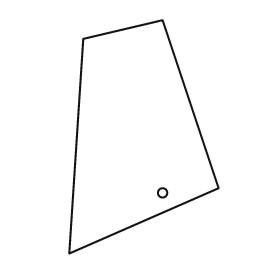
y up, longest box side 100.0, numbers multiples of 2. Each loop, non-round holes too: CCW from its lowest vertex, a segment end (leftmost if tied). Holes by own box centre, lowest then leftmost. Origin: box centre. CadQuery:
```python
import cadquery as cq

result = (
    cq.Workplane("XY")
    .moveTo(-32.0, -50.0)
    .lineTo(32.0, -22.0)
    .lineTo(8.0, 50.0)
    .lineTo(-26.0, 42.0)
    .close()
    .moveTo(8.0, -24.0)
    .circle(2.0)
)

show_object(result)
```